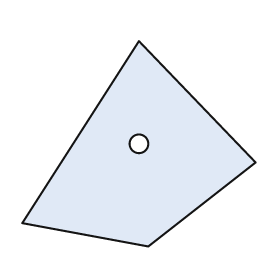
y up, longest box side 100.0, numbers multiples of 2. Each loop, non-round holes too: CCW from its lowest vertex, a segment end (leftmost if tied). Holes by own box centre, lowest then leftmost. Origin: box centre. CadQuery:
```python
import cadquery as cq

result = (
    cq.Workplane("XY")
    .moveTo(4.0, -44.0)
    .lineTo(50.0, -8.0)
    .lineTo(0.0, 44.0)
    .lineTo(-50.0, -34.0)
    .close()
    .moveTo(0.0, 0.0)
    .circle(4.0)
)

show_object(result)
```